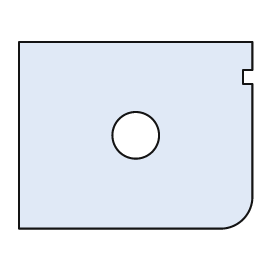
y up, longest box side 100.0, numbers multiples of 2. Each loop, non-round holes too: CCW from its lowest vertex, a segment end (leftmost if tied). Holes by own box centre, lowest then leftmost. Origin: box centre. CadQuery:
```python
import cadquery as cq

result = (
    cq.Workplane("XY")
    .moveTo(-50.0, -40.0)
    .lineTo(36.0, -40.0)
    .threePointArc((46.0, -36.0), (50.0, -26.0))
    .lineTo(50.0, 22.0)
    .lineTo(46.0, 22.0)
    .lineTo(46.0, 28.0)
    .lineTo(50.0, 28.0)
    .lineTo(50.0, 40.0)
    .lineTo(-50.0, 40.0)
    .close()
    .moveTo(0.0, 0.0)
    .circle(10.0)
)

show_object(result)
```